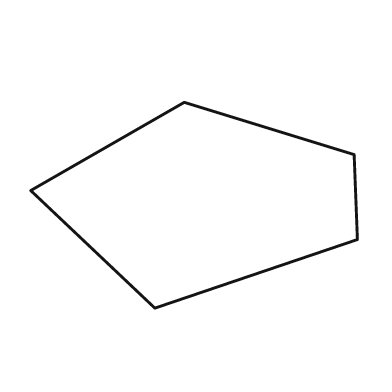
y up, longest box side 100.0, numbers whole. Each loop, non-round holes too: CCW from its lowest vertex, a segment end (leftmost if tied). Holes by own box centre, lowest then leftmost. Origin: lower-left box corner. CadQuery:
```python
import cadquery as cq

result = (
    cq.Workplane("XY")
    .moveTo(38.0, 0.0)
    .lineTo(100.0, 21.0)
    .lineTo(99.0, 47.0)
    .lineTo(47.0, 63.0)
    .lineTo(0.0, 36.0)
    .close()
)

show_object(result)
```